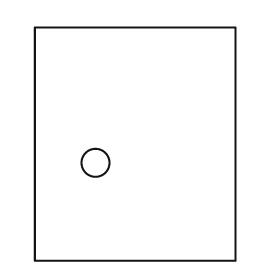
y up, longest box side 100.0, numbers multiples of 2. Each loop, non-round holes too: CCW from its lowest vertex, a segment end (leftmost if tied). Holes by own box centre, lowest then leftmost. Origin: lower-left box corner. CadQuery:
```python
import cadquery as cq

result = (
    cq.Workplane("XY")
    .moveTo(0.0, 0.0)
    .lineTo(86.0, 0.0)
    .lineTo(86.0, 100.0)
    .lineTo(0.0, 100.0)
    .close()
    .moveTo(26.0, 42.0)
    .circle(6.0)
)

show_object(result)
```